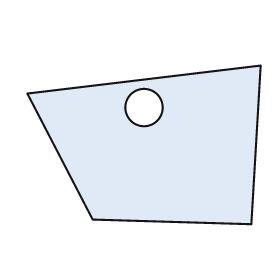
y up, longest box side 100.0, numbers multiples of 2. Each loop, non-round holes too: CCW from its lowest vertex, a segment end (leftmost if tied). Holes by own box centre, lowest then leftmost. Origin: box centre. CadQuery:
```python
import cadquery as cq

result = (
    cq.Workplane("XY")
    .moveTo(46.0, -34.0)
    .lineTo(50.0, 34.0)
    .lineTo(-50.0, 22.0)
    .lineTo(-22.0, -32.0)
    .close()
    .moveTo(0.0, 16.0)
    .circle(8.0)
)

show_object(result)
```